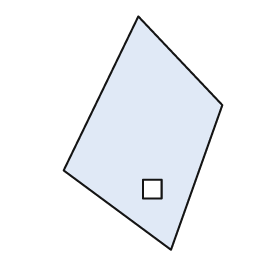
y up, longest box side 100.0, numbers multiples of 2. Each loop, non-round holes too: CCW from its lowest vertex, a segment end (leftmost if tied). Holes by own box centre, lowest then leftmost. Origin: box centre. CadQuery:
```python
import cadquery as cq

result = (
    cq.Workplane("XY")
    .moveTo(12.0, -50.0)
    .lineTo(34.0, 12.0)
    .lineTo(-2.0, 50.0)
    .lineTo(-34.0, -16.0)
    .close()
    .moveTo(0.0, -28.0)
    .lineTo(8.0, -28.0)
    .lineTo(8.0, -20.0)
    .lineTo(0.0, -20.0)
    .close()
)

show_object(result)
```